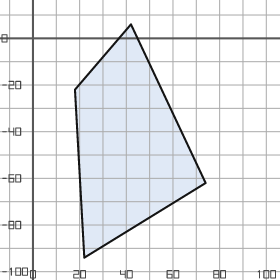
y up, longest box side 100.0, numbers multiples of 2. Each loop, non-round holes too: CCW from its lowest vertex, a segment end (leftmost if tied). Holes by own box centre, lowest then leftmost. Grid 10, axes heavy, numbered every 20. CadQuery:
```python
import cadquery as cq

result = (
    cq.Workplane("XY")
    .moveTo(22.0, -94.0)
    .lineTo(74.0, -62.0)
    .lineTo(42.0, 6.0)
    .lineTo(18.0, -22.0)
    .close()
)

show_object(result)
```